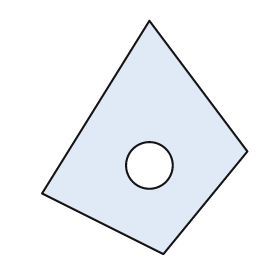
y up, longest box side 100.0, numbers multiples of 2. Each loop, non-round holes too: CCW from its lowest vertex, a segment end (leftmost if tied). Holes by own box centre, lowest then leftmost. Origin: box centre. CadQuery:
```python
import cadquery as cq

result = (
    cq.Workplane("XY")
    .moveTo(8.0, -50.0)
    .lineTo(44.0, -6.0)
    .lineTo(2.0, 50.0)
    .lineTo(-44.0, -24.0)
    .close()
    .moveTo(2.0, -12.0)
    .circle(10.0)
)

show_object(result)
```